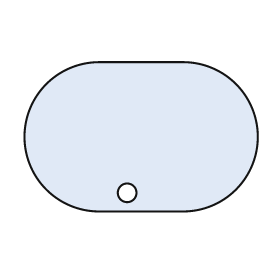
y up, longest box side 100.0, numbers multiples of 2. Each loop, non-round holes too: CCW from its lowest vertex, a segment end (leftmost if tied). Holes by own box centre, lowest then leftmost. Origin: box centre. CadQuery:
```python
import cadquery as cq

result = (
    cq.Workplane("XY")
    .moveTo(-18.0, -32.0)
    .lineTo(18.0, -32.0)
    .threePointArc((50.0, 0.0), (18.0, 32.0))
    .lineTo(-18.0, 32.0)
    .threePointArc((-50.0, 0.0), (-18.0, -32.0))
    .close()
    .moveTo(-6.0, -24.0)
    .circle(4.0)
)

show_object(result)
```